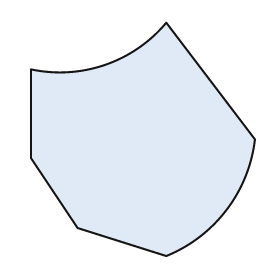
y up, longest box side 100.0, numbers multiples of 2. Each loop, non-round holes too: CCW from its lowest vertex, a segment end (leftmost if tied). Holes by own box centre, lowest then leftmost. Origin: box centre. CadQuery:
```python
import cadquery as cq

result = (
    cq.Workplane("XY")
    .moveTo(10.0, -50.0)
    .threePointArc((36.0, -30.0), (48.0, 0.0))
    .lineTo(10.0, 50.0)
    .threePointArc((-16.0, 32.0), (-48.0, 30.0))
    .lineTo(-48.0, -8.0)
    .lineTo(-28.0, -38.0)
    .close()
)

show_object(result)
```